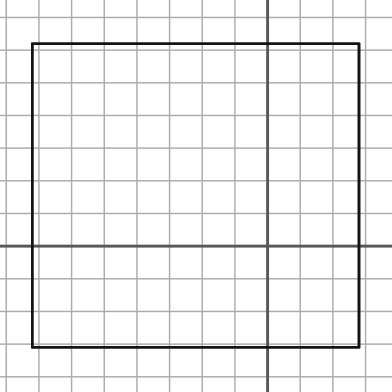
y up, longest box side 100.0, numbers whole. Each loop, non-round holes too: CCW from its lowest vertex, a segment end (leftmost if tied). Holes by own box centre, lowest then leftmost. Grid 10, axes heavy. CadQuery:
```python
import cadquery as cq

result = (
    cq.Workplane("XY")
    .moveTo(-72.0, -31.0)
    .lineTo(28.0, -31.0)
    .lineTo(28.0, 62.0)
    .lineTo(-72.0, 62.0)
    .close()
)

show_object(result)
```